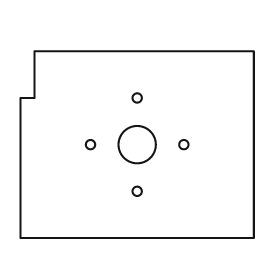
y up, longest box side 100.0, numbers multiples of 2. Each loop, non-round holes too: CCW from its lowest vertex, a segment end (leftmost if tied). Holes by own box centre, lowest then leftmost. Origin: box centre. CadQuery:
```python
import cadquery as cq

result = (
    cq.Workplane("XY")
    .moveTo(-50.0, -40.0)
    .lineTo(50.0, -40.0)
    .lineTo(50.0, 40.0)
    .lineTo(-44.0, 40.0)
    .lineTo(-44.0, 20.0)
    .lineTo(-50.0, 20.0)
    .close()
    .moveTo(0.0, -20.0)
    .circle(2.0)
    .moveTo(-20.0, 0.0)
    .circle(2.0)
    .moveTo(0.0, 0.0)
    .circle(8.0)
    .moveTo(20.0, 0.0)
    .circle(2.0)
    .moveTo(0.0, 20.0)
    .circle(2.0)
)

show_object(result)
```